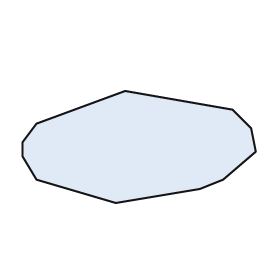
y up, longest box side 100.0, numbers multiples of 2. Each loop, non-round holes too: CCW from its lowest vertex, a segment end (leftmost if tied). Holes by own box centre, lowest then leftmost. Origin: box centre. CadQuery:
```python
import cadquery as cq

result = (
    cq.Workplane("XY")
    .moveTo(-10.0, -24.0)
    .lineTo(26.0, -18.0)
    .lineTo(36.0, -14.0)
    .lineTo(50.0, -2.0)
    .lineTo(48.0, 8.0)
    .lineTo(40.0, 16.0)
    .lineTo(-6.0, 24.0)
    .lineTo(-44.0, 10.0)
    .lineTo(-50.0, 2.0)
    .lineTo(-50.0, -4.0)
    .lineTo(-44.0, -14.0)
    .close()
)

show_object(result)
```